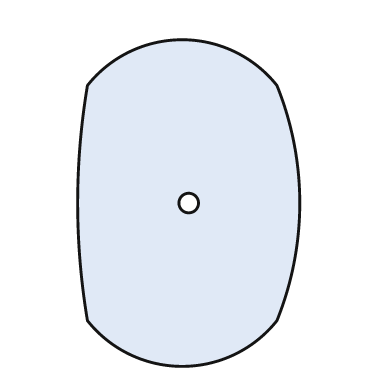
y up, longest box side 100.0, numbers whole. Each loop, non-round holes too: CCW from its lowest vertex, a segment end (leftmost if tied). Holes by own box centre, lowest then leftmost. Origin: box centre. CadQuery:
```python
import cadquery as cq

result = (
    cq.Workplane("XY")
    .moveTo(-31.0, -36.0)
    .threePointArc((-2.0, -50.0), (27.0, -36.0))
    .threePointArc((34.0, 0.0), (27.0, 36.0))
    .threePointArc((-2.0, 50.0), (-31.0, 36.0))
    .threePointArc((-34.0, 0.0), (-31.0, -36.0))
    .close()
    .moveTo(0.0, 0.0)
    .circle(3.0)
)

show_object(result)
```